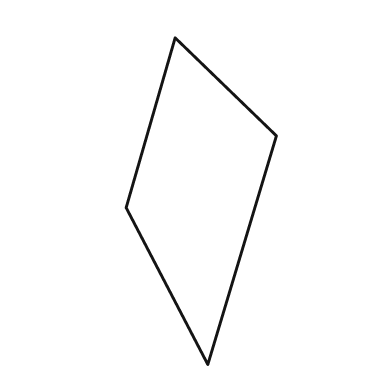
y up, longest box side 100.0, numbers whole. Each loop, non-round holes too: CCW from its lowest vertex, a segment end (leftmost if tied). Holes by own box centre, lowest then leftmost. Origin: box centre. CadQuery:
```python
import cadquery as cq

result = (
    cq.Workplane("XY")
    .moveTo(2.0, -50.0)
    .lineTo(23.0, 20.0)
    .lineTo(-8.0, 50.0)
    .lineTo(-23.0, -2.0)
    .close()
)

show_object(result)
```